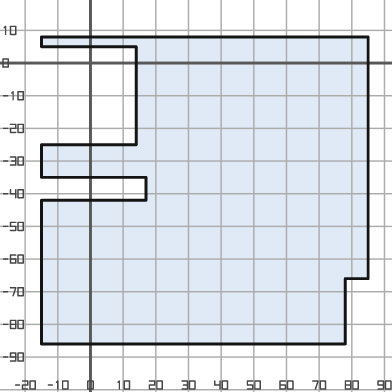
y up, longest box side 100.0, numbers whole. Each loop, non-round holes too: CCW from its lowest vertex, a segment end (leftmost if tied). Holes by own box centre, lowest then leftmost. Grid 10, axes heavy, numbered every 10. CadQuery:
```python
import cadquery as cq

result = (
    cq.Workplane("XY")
    .moveTo(-15.0, -86.0)
    .lineTo(78.0, -86.0)
    .lineTo(78.0, -66.0)
    .lineTo(85.0, -66.0)
    .lineTo(85.0, 8.0)
    .lineTo(-15.0, 8.0)
    .lineTo(-15.0, 5.0)
    .lineTo(14.0, 5.0)
    .lineTo(14.0, -25.0)
    .lineTo(-15.0, -25.0)
    .lineTo(-15.0, -35.0)
    .lineTo(17.0, -35.0)
    .lineTo(17.0, -42.0)
    .lineTo(-15.0, -42.0)
    .close()
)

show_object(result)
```